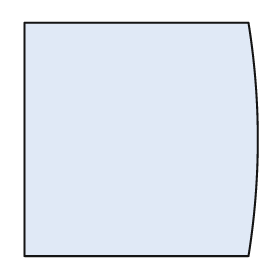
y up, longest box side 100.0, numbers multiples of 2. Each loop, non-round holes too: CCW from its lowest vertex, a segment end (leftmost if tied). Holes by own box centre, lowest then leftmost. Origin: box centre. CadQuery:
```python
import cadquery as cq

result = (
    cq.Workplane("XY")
    .moveTo(-50.0, -50.0)
    .lineTo(46.0, -50.0)
    .threePointArc((50.0, 0.0), (46.0, 50.0))
    .lineTo(-50.0, 50.0)
    .close()
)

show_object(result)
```